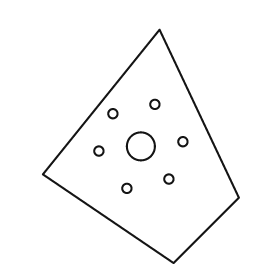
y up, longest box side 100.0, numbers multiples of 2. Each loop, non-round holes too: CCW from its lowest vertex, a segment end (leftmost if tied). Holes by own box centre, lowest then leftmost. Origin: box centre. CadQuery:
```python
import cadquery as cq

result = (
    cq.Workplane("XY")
    .moveTo(14.0, -50.0)
    .lineTo(42.0, -22.0)
    .lineTo(8.0, 50.0)
    .lineTo(-42.0, -12.0)
    .close()
    .moveTo(-6.0, -18.0)
    .circle(2.0)
    .moveTo(12.0, -14.0)
    .circle(2.0)
    .moveTo(-18.0, -2.0)
    .circle(2.0)
    .moveTo(0.0, 0.0)
    .circle(6.0)
    .moveTo(18.0, 2.0)
    .circle(2.0)
    .moveTo(-12.0, 14.0)
    .circle(2.0)
    .moveTo(6.0, 18.0)
    .circle(2.0)
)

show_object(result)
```